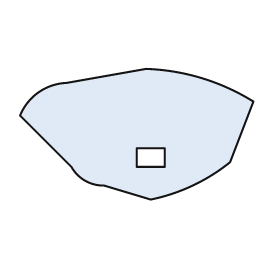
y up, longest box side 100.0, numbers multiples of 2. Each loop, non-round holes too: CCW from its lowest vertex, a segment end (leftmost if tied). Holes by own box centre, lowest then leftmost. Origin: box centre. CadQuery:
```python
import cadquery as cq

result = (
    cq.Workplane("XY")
    .moveTo(6.0, -28.0)
    .threePointArc((24.0, -22.0), (40.0, -12.0))
    .lineTo(50.0, 14.0)
    .threePointArc((28.0, 24.0), (4.0, 28.0))
    .lineTo(-30.0, 22.0)
    .threePointArc((-42.0, 18.0), (-50.0, 8.0))
    .lineTo(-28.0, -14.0)
    .threePointArc((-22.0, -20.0), (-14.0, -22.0))
    .close()
    .moveTo(0.0, -14.0)
    .lineTo(12.0, -14.0)
    .lineTo(12.0, -6.0)
    .lineTo(0.0, -6.0)
    .close()
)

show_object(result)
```